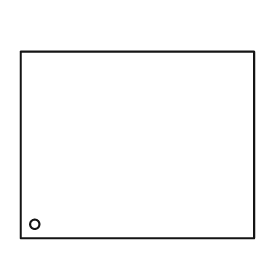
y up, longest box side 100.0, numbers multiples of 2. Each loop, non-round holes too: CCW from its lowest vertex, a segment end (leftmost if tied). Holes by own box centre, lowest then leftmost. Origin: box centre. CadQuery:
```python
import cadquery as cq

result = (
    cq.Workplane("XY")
    .moveTo(-50.0, -40.0)
    .lineTo(50.0, -40.0)
    .lineTo(50.0, 40.0)
    .lineTo(-50.0, 40.0)
    .close()
    .moveTo(-44.0, -34.0)
    .circle(2.0)
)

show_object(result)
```